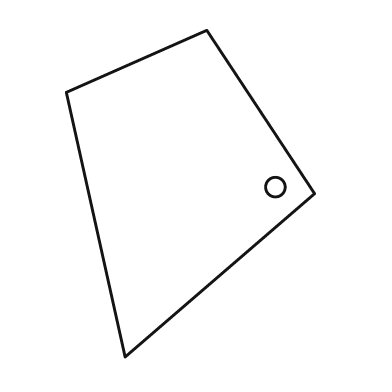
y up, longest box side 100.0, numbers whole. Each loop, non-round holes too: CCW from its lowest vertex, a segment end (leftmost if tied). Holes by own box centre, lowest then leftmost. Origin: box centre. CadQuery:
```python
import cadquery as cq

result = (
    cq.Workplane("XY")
    .moveTo(-20.0, -50.0)
    .lineTo(38.0, 0.0)
    .lineTo(5.0, 50.0)
    .lineTo(-38.0, 31.0)
    .close()
    .moveTo(26.0, 2.0)
    .circle(3.0)
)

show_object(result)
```